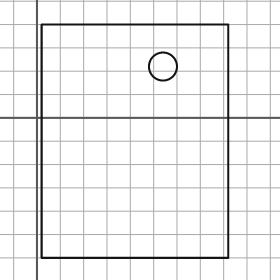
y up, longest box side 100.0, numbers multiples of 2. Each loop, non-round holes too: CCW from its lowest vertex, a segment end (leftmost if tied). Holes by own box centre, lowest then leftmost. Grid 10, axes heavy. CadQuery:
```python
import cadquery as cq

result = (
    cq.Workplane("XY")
    .moveTo(2.0, -60.0)
    .lineTo(82.0, -60.0)
    .lineTo(82.0, 40.0)
    .lineTo(2.0, 40.0)
    .close()
    .moveTo(54.0, 22.0)
    .circle(6.0)
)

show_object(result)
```